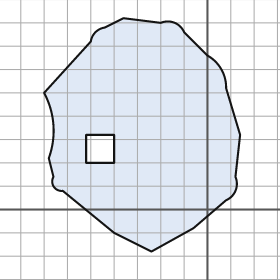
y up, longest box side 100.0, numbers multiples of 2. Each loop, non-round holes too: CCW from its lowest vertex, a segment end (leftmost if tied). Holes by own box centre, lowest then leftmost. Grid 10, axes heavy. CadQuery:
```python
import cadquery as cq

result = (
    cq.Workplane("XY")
    .moveTo(-24.0, -18.0)
    .lineTo(-6.0, -8.0)
    .lineTo(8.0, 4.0)
    .threePointArc((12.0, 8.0), (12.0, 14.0))
    .lineTo(14.0, 32.0)
    .lineTo(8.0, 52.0)
    .threePointArc((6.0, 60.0), (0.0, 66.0))
    .lineTo(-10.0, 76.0)
    .threePointArc((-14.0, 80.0), (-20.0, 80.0))
    .lineTo(-36.0, 82.0)
    .lineTo(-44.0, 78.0)
    .threePointArc((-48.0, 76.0), (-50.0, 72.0))
    .lineTo(-70.0, 50.0)
    .threePointArc((-66.0, 36.0), (-68.0, 22.0))
    .lineTo(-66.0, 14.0)
    .threePointArc((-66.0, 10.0), (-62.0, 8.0))
    .lineTo(-40.0, -10.0)
    .close()
    .moveTo(-52.0, 20.0)
    .lineTo(-40.0, 20.0)
    .lineTo(-40.0, 32.0)
    .lineTo(-52.0, 32.0)
    .close()
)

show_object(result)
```